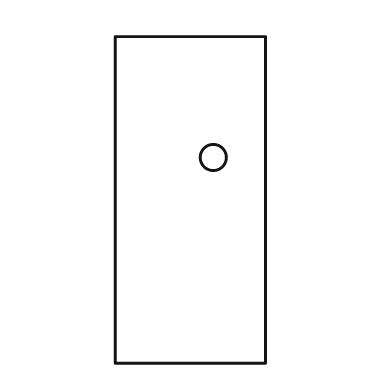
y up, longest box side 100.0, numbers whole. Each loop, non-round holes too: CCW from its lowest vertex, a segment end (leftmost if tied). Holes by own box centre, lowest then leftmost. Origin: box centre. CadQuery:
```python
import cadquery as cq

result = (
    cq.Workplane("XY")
    .moveTo(-23.0, -50.0)
    .lineTo(23.0, -50.0)
    .lineTo(23.0, 50.0)
    .lineTo(-23.0, 50.0)
    .close()
    .moveTo(7.0, 13.0)
    .circle(4.0)
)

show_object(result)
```